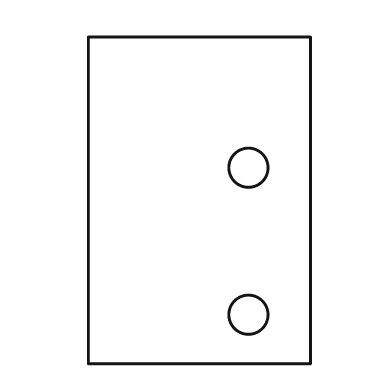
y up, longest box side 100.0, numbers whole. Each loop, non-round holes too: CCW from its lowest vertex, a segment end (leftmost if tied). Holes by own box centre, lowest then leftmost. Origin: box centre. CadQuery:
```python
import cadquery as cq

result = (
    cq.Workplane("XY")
    .moveTo(-34.0, -50.0)
    .lineTo(34.0, -50.0)
    .lineTo(34.0, 50.0)
    .lineTo(-34.0, 50.0)
    .close()
    .moveTo(15.0, -35.0)
    .circle(6.0)
    .moveTo(15.0, 10.0)
    .circle(6.0)
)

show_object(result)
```